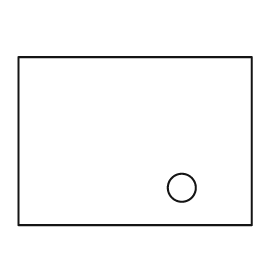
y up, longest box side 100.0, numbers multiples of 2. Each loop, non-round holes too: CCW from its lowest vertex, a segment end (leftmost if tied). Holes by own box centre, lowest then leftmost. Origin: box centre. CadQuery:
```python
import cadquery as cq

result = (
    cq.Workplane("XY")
    .moveTo(-50.0, -36.0)
    .lineTo(50.0, -36.0)
    .lineTo(50.0, 36.0)
    .lineTo(-50.0, 36.0)
    .close()
    .moveTo(20.0, -20.0)
    .circle(6.0)
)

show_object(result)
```